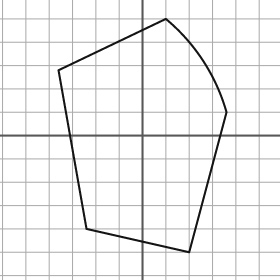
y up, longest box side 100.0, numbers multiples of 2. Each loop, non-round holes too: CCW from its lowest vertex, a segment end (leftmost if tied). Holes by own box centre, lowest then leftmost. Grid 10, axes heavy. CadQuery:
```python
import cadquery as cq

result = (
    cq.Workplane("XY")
    .moveTo(20.0, -50.0)
    .lineTo(36.0, 10.0)
    .threePointArc((26.0, 32.0), (10.0, 50.0))
    .lineTo(-36.0, 28.0)
    .lineTo(-24.0, -40.0)
    .close()
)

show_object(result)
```